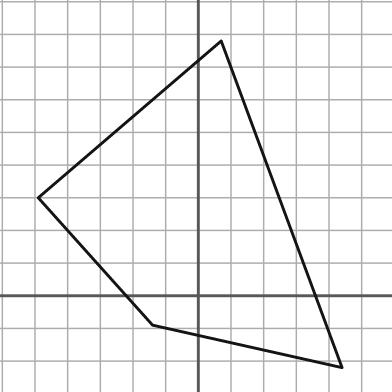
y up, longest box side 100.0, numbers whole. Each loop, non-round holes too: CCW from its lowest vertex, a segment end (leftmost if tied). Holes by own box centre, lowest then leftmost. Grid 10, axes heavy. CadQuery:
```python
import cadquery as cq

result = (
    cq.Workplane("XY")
    .moveTo(44.0, -22.0)
    .lineTo(7.0, 78.0)
    .lineTo(-49.0, 30.0)
    .lineTo(-14.0, -9.0)
    .close()
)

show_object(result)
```